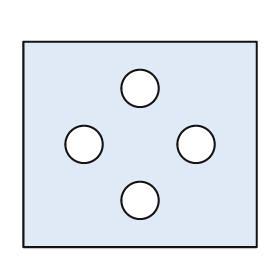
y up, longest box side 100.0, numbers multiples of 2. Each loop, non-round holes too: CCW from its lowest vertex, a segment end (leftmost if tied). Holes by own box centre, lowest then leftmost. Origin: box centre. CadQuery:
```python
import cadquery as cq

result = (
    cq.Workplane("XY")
    .moveTo(-50.0, -44.0)
    .lineTo(50.0, -44.0)
    .lineTo(50.0, 44.0)
    .lineTo(-50.0, 44.0)
    .close()
    .moveTo(0.0, -24.0)
    .circle(8.0)
    .moveTo(-24.0, 0.0)
    .circle(8.0)
    .moveTo(24.0, 0.0)
    .circle(8.0)
    .moveTo(0.0, 24.0)
    .circle(8.0)
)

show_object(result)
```